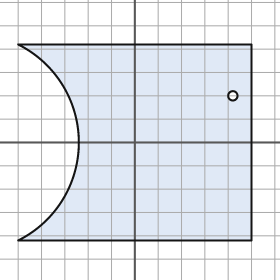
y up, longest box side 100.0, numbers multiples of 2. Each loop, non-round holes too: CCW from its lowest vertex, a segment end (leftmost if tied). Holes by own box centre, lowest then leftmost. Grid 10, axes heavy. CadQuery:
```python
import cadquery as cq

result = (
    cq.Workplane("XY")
    .moveTo(-50.0, -42.0)
    .lineTo(50.0, -42.0)
    .lineTo(50.0, 42.0)
    .lineTo(-50.0, 42.0)
    .threePointArc((-24.0, 0.0), (-50.0, -42.0))
    .close()
    .moveTo(42.0, 20.0)
    .circle(2.0)
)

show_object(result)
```